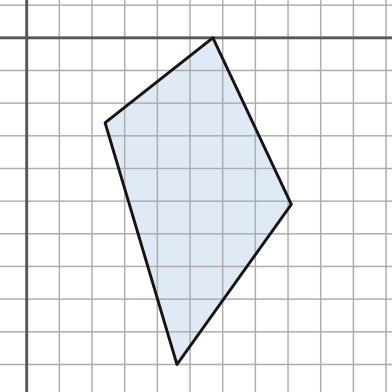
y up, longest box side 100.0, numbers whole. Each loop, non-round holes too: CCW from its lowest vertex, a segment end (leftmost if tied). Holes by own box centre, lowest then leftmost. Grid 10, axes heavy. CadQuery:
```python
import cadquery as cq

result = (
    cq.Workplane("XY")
    .moveTo(46.0, -100.0)
    .lineTo(81.0, -51.0)
    .lineTo(57.0, 0.0)
    .lineTo(24.0, -26.0)
    .close()
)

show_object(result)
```